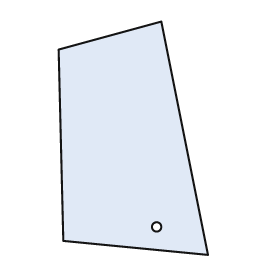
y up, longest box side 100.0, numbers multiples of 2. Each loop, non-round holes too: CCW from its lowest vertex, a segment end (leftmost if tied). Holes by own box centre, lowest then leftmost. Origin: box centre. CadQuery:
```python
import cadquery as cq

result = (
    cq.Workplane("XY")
    .moveTo(32.0, -50.0)
    .lineTo(12.0, 50.0)
    .lineTo(-32.0, 38.0)
    .lineTo(-30.0, -44.0)
    .close()
    .moveTo(10.0, -38.0)
    .circle(2.0)
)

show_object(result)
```